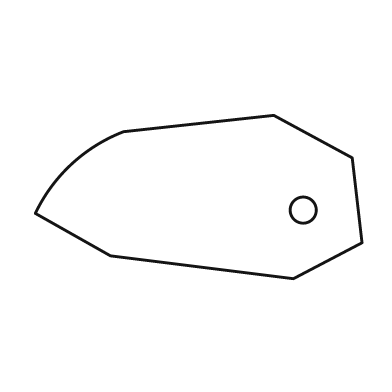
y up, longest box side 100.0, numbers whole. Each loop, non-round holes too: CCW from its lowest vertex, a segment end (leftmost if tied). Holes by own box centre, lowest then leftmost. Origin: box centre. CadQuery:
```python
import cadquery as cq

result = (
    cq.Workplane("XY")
    .moveTo(29.0, -25.0)
    .lineTo(50.0, -14.0)
    .lineTo(47.0, 12.0)
    .lineTo(23.0, 25.0)
    .lineTo(-23.0, 20.0)
    .threePointArc((-39.0, 10.0), (-50.0, -5.0))
    .lineTo(-27.0, -18.0)
    .close()
    .moveTo(32.0, -4.0)
    .circle(4.0)
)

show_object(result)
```